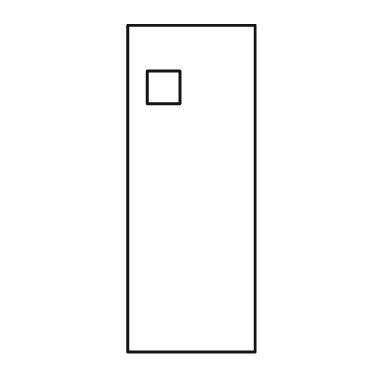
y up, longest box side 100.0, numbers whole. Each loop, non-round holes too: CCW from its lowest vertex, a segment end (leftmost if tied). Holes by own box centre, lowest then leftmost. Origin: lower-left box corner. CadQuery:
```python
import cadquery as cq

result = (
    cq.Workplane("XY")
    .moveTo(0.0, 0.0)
    .lineTo(39.0, 0.0)
    .lineTo(39.0, 100.0)
    .lineTo(0.0, 100.0)
    .close()
    .moveTo(6.0, 76.0)
    .lineTo(16.0, 76.0)
    .lineTo(16.0, 86.0)
    .lineTo(6.0, 86.0)
    .close()
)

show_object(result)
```